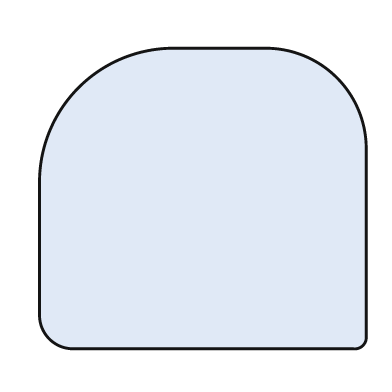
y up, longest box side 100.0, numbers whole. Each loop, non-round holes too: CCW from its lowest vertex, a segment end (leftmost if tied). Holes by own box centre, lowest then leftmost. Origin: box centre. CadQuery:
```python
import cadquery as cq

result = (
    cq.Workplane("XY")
    .moveTo(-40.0, -46.0)
    .lineTo(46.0, -46.0)
    .threePointArc((49.0, -45.0), (50.0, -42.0))
    .lineTo(50.0, 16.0)
    .threePointArc((41.0, 37.0), (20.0, 46.0))
    .lineTo(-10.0, 46.0)
    .threePointArc((-38.0, 34.0), (-50.0, 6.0))
    .lineTo(-50.0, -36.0)
    .threePointArc((-47.0, -43.0), (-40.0, -46.0))
    .close()
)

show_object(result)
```